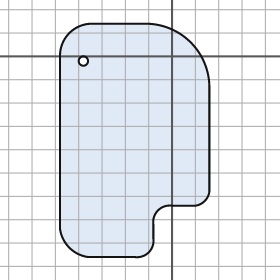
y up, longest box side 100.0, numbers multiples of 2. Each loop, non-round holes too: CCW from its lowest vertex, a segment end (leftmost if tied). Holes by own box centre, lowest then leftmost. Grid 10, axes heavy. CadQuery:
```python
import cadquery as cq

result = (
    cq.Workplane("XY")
    .moveTo(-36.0, -86.0)
    .lineTo(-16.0, -86.0)
    .threePointArc((-10.0, -84.0), (-8.0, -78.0))
    .lineTo(-8.0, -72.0)
    .threePointArc((-6.0, -66.0), (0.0, -64.0))
    .lineTo(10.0, -64.0)
    .threePointArc((14.0, -62.0), (16.0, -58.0))
    .lineTo(16.0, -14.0)
    .threePointArc((8.0, 6.0), (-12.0, 14.0))
    .lineTo(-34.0, 14.0)
    .threePointArc((-44.0, 10.0), (-48.0, 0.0))
    .lineTo(-48.0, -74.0)
    .threePointArc((-44.0, -82.0), (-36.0, -86.0))
    .close()
    .moveTo(-38.0, -2.0)
    .circle(2.0)
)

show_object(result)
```